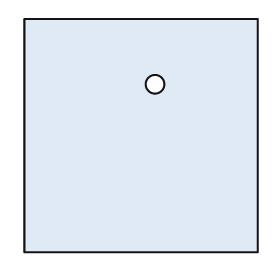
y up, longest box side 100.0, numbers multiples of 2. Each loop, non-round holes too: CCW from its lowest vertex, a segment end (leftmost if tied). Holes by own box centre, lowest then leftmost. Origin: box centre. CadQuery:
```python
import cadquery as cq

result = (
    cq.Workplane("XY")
    .moveTo(-50.0, -50.0)
    .lineTo(50.0, -50.0)
    .lineTo(50.0, 50.0)
    .lineTo(-50.0, 50.0)
    .close()
    .moveTo(6.0, 22.0)
    .circle(4.0)
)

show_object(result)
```